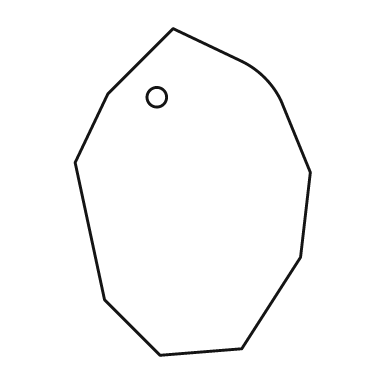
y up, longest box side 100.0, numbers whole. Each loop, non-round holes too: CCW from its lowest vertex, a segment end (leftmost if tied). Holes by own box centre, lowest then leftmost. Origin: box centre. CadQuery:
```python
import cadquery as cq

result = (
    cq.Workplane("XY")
    .moveTo(-10.0, -50.0)
    .lineTo(15.0, -48.0)
    .lineTo(33.0, -20.0)
    .lineTo(36.0, 6.0)
    .lineTo(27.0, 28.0)
    .threePointArc((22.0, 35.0), (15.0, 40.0))
    .lineTo(-6.0, 50.0)
    .lineTo(-26.0, 30.0)
    .lineTo(-36.0, 9.0)
    .lineTo(-27.0, -33.0)
    .close()
    .moveTo(-11.0, 29.0)
    .circle(3.0)
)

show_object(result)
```